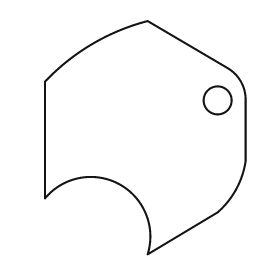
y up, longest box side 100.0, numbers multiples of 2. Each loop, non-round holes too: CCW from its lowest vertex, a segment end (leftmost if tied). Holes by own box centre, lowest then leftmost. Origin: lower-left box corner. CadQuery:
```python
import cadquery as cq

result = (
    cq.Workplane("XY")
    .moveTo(44.0, 0.0)
    .lineTo(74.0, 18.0)
    .threePointArc((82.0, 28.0), (86.0, 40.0))
    .lineTo(86.0, 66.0)
    .threePointArc((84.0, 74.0), (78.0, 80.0))
    .lineTo(44.0, 100.0)
    .threePointArc((20.0, 90.0), (0.0, 74.0))
    .lineTo(0.0, 24.0)
    .threePointArc((32.0, 30.0), (44.0, 0.0))
    .close()
    .moveTo(74.0, 66.0)
    .circle(6.0)
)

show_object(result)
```